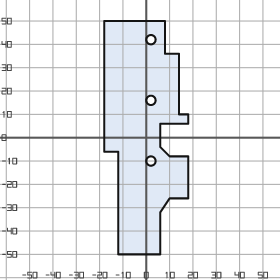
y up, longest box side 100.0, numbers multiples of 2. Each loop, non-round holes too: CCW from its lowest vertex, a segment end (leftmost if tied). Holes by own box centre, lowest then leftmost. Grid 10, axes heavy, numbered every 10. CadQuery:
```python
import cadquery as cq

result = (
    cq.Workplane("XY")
    .moveTo(-12.0, -50.0)
    .lineTo(6.0, -50.0)
    .lineTo(6.0, -32.0)
    .lineTo(10.0, -26.0)
    .lineTo(18.0, -26.0)
    .lineTo(18.0, -8.0)
    .lineTo(10.0, -8.0)
    .lineTo(6.0, -4.0)
    .lineTo(6.0, 6.0)
    .lineTo(18.0, 6.0)
    .lineTo(18.0, 10.0)
    .lineTo(14.0, 10.0)
    .lineTo(14.0, 36.0)
    .lineTo(8.0, 36.0)
    .lineTo(8.0, 50.0)
    .lineTo(-18.0, 50.0)
    .lineTo(-18.0, -6.0)
    .lineTo(-12.0, -6.0)
    .close()
    .moveTo(2.0, -10.0)
    .circle(2.0)
    .moveTo(2.0, 16.0)
    .circle(2.0)
    .moveTo(2.0, 42.0)
    .circle(2.0)
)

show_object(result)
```